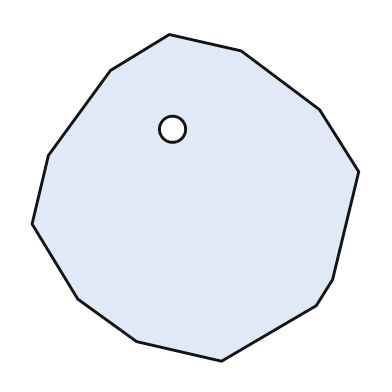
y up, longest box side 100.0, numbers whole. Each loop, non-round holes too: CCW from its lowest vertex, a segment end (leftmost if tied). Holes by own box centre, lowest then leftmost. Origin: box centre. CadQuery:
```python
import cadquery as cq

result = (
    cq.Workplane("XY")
    .moveTo(8.0, -50.0)
    .lineTo(37.0, -33.0)
    .lineTo(42.0, -25.0)
    .lineTo(50.0, 8.0)
    .lineTo(38.0, 27.0)
    .lineTo(14.0, 45.0)
    .lineTo(-8.0, 50.0)
    .lineTo(-26.0, 39.0)
    .lineTo(-45.0, 13.0)
    .lineTo(-50.0, -8.0)
    .lineTo(-36.0, -31.0)
    .lineTo(-18.0, -44.0)
    .close()
    .moveTo(-7.0, 21.0)
    .circle(4.0)
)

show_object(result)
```